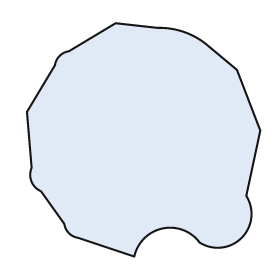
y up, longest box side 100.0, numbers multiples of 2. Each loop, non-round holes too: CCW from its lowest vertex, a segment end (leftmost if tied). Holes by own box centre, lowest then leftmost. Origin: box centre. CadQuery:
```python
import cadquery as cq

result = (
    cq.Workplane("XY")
    .moveTo(-4.0, -50.0)
    .threePointArc((8.0, -38.0), (24.0, -44.0))
    .threePointArc((42.0, -42.0), (44.0, -24.0))
    .lineTo(50.0, 4.0)
    .lineTo(40.0, 30.0)
    .lineTo(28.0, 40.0)
    .threePointArc((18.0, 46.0), (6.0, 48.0))
    .lineTo(-12.0, 50.0)
    .lineTo(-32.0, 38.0)
    .threePointArc((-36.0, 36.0), (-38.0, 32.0))
    .lineTo(-50.0, 12.0)
    .lineTo(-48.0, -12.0)
    .threePointArc((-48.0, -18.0), (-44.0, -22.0))
    .lineTo(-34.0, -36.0)
    .threePointArc((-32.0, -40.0), (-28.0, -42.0))
    .close()
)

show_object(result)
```